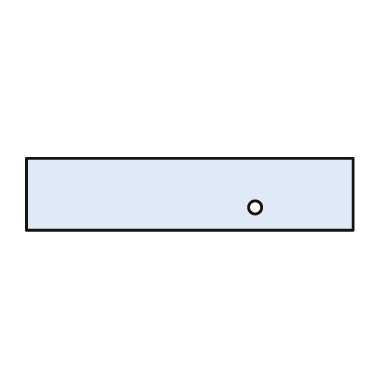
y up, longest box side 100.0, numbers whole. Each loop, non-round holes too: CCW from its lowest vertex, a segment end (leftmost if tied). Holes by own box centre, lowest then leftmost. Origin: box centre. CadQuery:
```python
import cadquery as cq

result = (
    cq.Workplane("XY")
    .moveTo(-50.0, -11.0)
    .lineTo(50.0, -11.0)
    .lineTo(50.0, 11.0)
    .lineTo(-50.0, 11.0)
    .close()
    .moveTo(20.0, -4.0)
    .circle(2.0)
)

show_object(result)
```